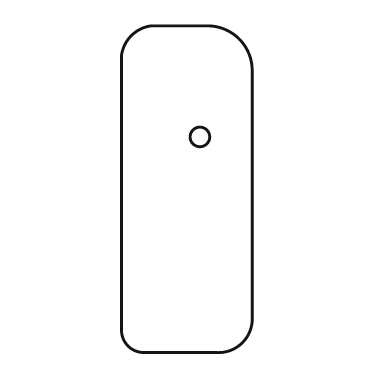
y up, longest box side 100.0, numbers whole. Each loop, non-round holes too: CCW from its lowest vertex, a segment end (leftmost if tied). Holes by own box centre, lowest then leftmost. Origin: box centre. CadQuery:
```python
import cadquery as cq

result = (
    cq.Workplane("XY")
    .moveTo(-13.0, -50.0)
    .lineTo(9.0, -50.0)
    .threePointArc((17.0, -47.0), (20.0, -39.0))
    .lineTo(20.0, 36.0)
    .threePointArc((16.0, 46.0), (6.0, 50.0))
    .lineTo(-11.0, 50.0)
    .threePointArc((-17.0, 47.0), (-20.0, 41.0))
    .lineTo(-20.0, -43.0)
    .threePointArc((-18.0, -48.0), (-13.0, -50.0))
    .close()
    .moveTo(4.0, 16.0)
    .circle(3.0)
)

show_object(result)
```